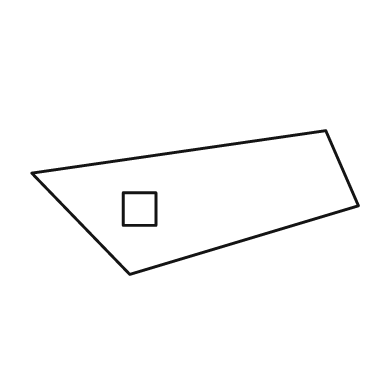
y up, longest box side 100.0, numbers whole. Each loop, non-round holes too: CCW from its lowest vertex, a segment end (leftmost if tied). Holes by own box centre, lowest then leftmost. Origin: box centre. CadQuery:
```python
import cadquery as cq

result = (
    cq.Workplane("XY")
    .moveTo(-20.0, -22.0)
    .lineTo(50.0, -1.0)
    .lineTo(40.0, 22.0)
    .lineTo(-50.0, 9.0)
    .close()
    .moveTo(-22.0, -7.0)
    .lineTo(-12.0, -7.0)
    .lineTo(-12.0, 3.0)
    .lineTo(-22.0, 3.0)
    .close()
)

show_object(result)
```